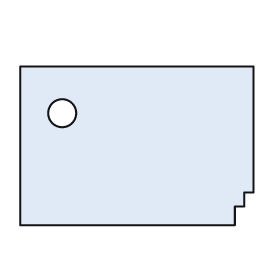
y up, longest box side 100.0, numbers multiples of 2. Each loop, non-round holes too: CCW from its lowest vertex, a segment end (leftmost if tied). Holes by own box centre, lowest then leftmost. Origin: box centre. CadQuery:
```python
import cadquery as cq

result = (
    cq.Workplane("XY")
    .moveTo(-50.0, -34.0)
    .lineTo(42.0, -34.0)
    .lineTo(42.0, -26.0)
    .lineTo(46.0, -26.0)
    .lineTo(46.0, -20.0)
    .lineTo(50.0, -20.0)
    .lineTo(50.0, 34.0)
    .lineTo(-50.0, 34.0)
    .close()
    .moveTo(-32.0, 14.0)
    .circle(6.0)
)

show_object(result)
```